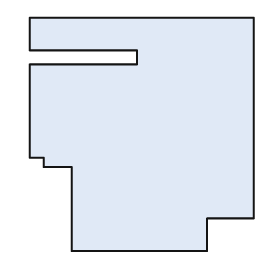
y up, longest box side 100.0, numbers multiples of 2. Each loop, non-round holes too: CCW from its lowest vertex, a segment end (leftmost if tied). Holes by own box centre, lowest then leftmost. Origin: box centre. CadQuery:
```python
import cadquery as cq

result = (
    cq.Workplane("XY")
    .moveTo(-30.0, -50.0)
    .lineTo(28.0, -50.0)
    .lineTo(28.0, -36.0)
    .lineTo(48.0, -36.0)
    .lineTo(48.0, 50.0)
    .lineTo(-48.0, 50.0)
    .lineTo(-48.0, 36.0)
    .lineTo(-2.0, 36.0)
    .lineTo(-2.0, 30.0)
    .lineTo(-48.0, 30.0)
    .lineTo(-48.0, -10.0)
    .lineTo(-42.0, -10.0)
    .lineTo(-42.0, -14.0)
    .lineTo(-30.0, -14.0)
    .close()
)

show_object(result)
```